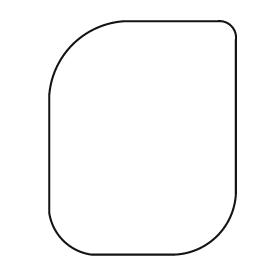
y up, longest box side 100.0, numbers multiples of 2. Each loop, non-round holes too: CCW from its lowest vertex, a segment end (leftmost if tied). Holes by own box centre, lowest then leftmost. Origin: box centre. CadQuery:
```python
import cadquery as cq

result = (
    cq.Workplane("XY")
    .moveTo(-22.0, -50.0)
    .lineTo(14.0, -50.0)
    .threePointArc((32.0, -42.0), (40.0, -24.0))
    .lineTo(40.0, 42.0)
    .threePointArc((38.0, 48.0), (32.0, 50.0))
    .lineTo(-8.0, 50.0)
    .threePointArc((-30.0, 40.0), (-40.0, 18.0))
    .lineTo(-40.0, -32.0)
    .threePointArc((-34.0, -44.0), (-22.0, -50.0))
    .close()
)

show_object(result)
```